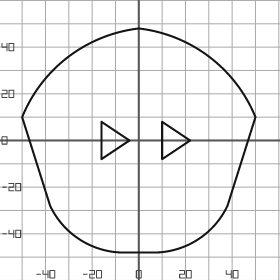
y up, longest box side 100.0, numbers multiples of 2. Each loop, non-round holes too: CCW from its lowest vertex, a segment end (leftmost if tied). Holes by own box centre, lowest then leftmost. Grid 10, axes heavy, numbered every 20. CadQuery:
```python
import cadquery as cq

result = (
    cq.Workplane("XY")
    .moveTo(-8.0, -48.0)
    .lineTo(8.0, -48.0)
    .threePointArc((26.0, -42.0), (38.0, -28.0))
    .lineTo(50.0, 10.0)
    .threePointArc((30.0, 36.0), (0.0, 48.0))
    .threePointArc((-30.0, 36.0), (-50.0, 10.0))
    .lineTo(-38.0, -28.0)
    .threePointArc((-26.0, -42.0), (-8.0, -48.0))
    .close()
    .moveTo(-16.0, -8.0)
    .lineTo(-4.0, 0.0)
    .lineTo(-16.0, 8.0)
    .close()
    .moveTo(10.0, -8.0)
    .lineTo(22.0, 0.0)
    .lineTo(10.0, 8.0)
    .close()
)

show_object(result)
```